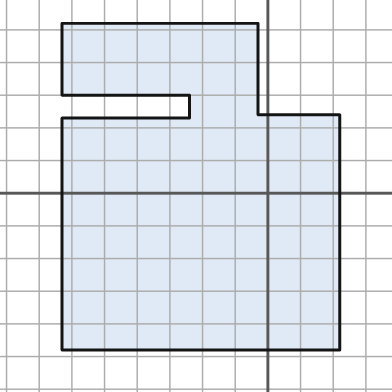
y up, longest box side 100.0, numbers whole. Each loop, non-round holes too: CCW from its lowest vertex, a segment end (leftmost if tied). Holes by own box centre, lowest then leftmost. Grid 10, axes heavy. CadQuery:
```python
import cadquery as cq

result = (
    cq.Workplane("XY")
    .moveTo(-63.0, -48.0)
    .lineTo(22.0, -48.0)
    .lineTo(22.0, 24.0)
    .lineTo(-3.0, 24.0)
    .lineTo(-3.0, 52.0)
    .lineTo(-63.0, 52.0)
    .lineTo(-63.0, 30.0)
    .lineTo(-24.0, 30.0)
    .lineTo(-24.0, 23.0)
    .lineTo(-63.0, 23.0)
    .close()
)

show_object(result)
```